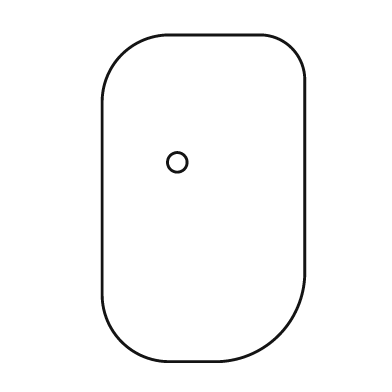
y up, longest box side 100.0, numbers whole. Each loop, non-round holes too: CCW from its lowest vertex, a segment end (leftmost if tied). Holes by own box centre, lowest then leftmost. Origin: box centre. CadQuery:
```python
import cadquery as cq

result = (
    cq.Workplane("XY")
    .moveTo(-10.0, -50.0)
    .lineTo(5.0, -50.0)
    .threePointArc((23.0, -42.0), (31.0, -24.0))
    .lineTo(31.0, 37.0)
    .threePointArc((27.0, 46.0), (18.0, 50.0))
    .lineTo(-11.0, 50.0)
    .threePointArc((-25.0, 44.0), (-31.0, 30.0))
    .lineTo(-31.0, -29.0)
    .threePointArc((-25.0, -44.0), (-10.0, -50.0))
    .close()
    .moveTo(-8.0, 11.0)
    .circle(3.0)
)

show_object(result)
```